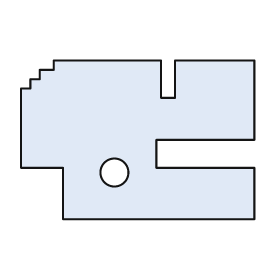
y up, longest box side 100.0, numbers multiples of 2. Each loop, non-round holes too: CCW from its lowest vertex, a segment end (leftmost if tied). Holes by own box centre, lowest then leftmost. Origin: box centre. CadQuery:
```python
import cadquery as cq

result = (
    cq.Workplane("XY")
    .moveTo(-32.0, -34.0)
    .lineTo(50.0, -34.0)
    .lineTo(50.0, -12.0)
    .lineTo(8.0, -12.0)
    .lineTo(8.0, 0.0)
    .lineTo(50.0, 0.0)
    .lineTo(50.0, 34.0)
    .lineTo(16.0, 34.0)
    .lineTo(16.0, 18.0)
    .lineTo(10.0, 18.0)
    .lineTo(10.0, 34.0)
    .lineTo(-36.0, 34.0)
    .lineTo(-36.0, 30.0)
    .lineTo(-42.0, 30.0)
    .lineTo(-42.0, 26.0)
    .lineTo(-46.0, 26.0)
    .lineTo(-46.0, 22.0)
    .lineTo(-50.0, 22.0)
    .lineTo(-50.0, -12.0)
    .lineTo(-32.0, -12.0)
    .close()
    .moveTo(-10.0, -14.0)
    .circle(6.0)
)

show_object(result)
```